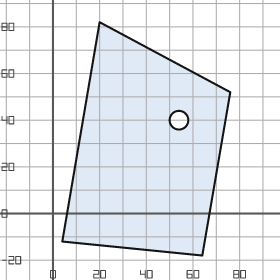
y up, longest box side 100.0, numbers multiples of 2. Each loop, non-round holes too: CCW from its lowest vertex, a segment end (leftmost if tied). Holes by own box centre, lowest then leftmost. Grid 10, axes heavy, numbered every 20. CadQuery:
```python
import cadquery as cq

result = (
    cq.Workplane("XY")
    .moveTo(64.0, -18.0)
    .lineTo(76.0, 52.0)
    .lineTo(20.0, 82.0)
    .lineTo(4.0, -12.0)
    .close()
    .moveTo(54.0, 40.0)
    .circle(4.0)
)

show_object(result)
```